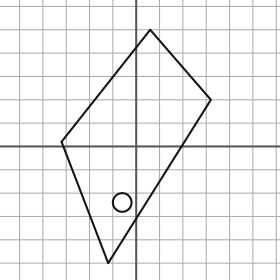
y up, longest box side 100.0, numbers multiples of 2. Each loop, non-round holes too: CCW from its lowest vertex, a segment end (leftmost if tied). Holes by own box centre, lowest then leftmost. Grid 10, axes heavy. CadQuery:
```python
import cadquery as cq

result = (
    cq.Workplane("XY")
    .moveTo(-12.0, -50.0)
    .lineTo(32.0, 20.0)
    .lineTo(6.0, 50.0)
    .lineTo(-32.0, 2.0)
    .close()
    .moveTo(-6.0, -24.0)
    .circle(4.0)
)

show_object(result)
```